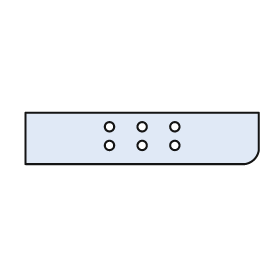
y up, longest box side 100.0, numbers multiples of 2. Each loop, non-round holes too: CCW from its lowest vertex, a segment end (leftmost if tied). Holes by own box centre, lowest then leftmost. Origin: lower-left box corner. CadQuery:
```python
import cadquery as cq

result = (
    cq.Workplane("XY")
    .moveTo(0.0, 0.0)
    .lineTo(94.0, 0.0)
    .threePointArc((98.0, 2.0), (100.0, 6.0))
    .lineTo(100.0, 22.0)
    .lineTo(0.0, 22.0)
    .close()
    .moveTo(36.0, 8.0)
    .circle(2.0)
    .moveTo(50.0, 8.0)
    .circle(2.0)
    .moveTo(64.0, 8.0)
    .circle(2.0)
    .moveTo(36.0, 16.0)
    .circle(2.0)
    .moveTo(50.0, 16.0)
    .circle(2.0)
    .moveTo(64.0, 16.0)
    .circle(2.0)
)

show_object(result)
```